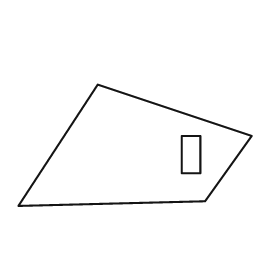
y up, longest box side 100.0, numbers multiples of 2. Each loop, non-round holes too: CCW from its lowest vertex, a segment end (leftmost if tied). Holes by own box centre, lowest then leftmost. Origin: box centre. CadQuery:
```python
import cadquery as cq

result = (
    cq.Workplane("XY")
    .moveTo(-50.0, -26.0)
    .lineTo(30.0, -24.0)
    .lineTo(50.0, 4.0)
    .lineTo(-16.0, 26.0)
    .close()
    .moveTo(20.0, -12.0)
    .lineTo(28.0, -12.0)
    .lineTo(28.0, 4.0)
    .lineTo(20.0, 4.0)
    .close()
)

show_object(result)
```